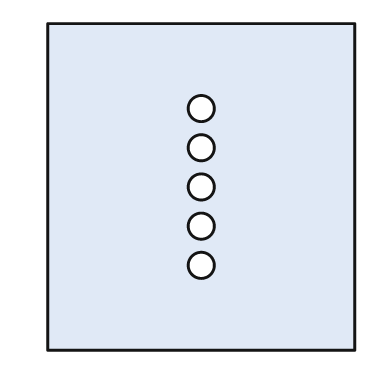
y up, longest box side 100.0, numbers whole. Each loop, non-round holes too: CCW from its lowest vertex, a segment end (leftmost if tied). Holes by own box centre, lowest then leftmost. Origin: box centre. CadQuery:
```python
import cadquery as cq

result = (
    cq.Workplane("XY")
    .moveTo(-47.0, -50.0)
    .lineTo(47.0, -50.0)
    .lineTo(47.0, 50.0)
    .lineTo(-47.0, 50.0)
    .close()
    .moveTo(0.0, -24.0)
    .circle(4.0)
    .moveTo(0.0, -12.0)
    .circle(4.0)
    .moveTo(0.0, 0.0)
    .circle(4.0)
    .moveTo(0.0, 12.0)
    .circle(4.0)
    .moveTo(0.0, 24.0)
    .circle(4.0)
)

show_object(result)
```